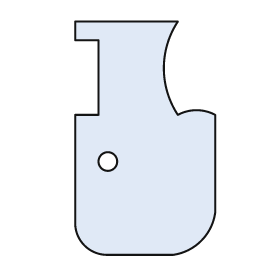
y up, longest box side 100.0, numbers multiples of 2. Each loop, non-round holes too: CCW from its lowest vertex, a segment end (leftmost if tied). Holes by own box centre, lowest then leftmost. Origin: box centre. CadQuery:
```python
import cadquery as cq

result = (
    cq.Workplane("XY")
    .moveTo(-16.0, -50.0)
    .lineTo(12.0, -50.0)
    .threePointArc((24.0, -44.0), (30.0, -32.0))
    .lineTo(30.0, 10.0)
    .threePointArc((22.0, 12.0), (14.0, 10.0))
    .threePointArc((8.0, 30.0), (14.0, 50.0))
    .lineTo(-30.0, 50.0)
    .lineTo(-30.0, 42.0)
    .lineTo(-20.0, 42.0)
    .lineTo(-20.0, 10.0)
    .lineTo(-30.0, 10.0)
    .lineTo(-30.0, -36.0)
    .threePointArc((-26.0, -46.0), (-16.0, -50.0))
    .close()
    .moveTo(-16.0, -10.0)
    .circle(4.0)
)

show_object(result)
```